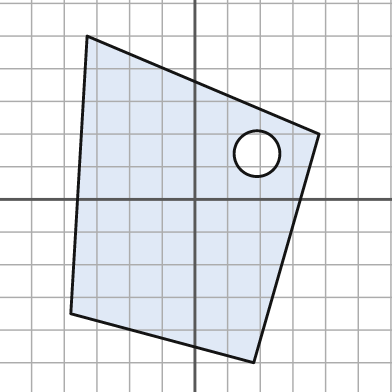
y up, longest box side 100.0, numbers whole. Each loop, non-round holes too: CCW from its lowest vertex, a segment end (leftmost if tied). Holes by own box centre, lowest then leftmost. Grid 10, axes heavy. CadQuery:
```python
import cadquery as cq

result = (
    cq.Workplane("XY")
    .moveTo(18.0, -50.0)
    .lineTo(38.0, 20.0)
    .lineTo(-33.0, 50.0)
    .lineTo(-38.0, -35.0)
    .close()
    .moveTo(19.0, 14.0)
    .circle(7.0)
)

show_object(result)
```